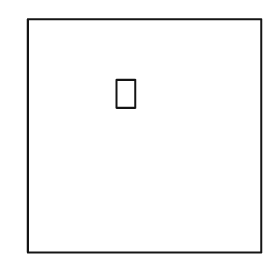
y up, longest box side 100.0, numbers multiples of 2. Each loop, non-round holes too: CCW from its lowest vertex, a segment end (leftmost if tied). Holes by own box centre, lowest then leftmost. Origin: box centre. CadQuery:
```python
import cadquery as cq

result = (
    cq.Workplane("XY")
    .moveTo(-50.0, -50.0)
    .lineTo(50.0, -50.0)
    .lineTo(50.0, 50.0)
    .lineTo(-50.0, 50.0)
    .close()
    .moveTo(-12.0, 12.0)
    .lineTo(-4.0, 12.0)
    .lineTo(-4.0, 24.0)
    .lineTo(-12.0, 24.0)
    .close()
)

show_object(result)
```